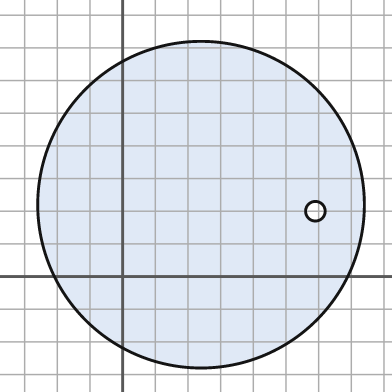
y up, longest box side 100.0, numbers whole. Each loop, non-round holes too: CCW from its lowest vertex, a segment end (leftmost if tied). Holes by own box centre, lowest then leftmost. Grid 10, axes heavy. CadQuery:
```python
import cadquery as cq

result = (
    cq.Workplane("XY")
    .moveTo(24.0, 22.0)
    .circle(50.0)
    .moveTo(59.0, 20.0)
    .circle(3.0)
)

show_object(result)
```